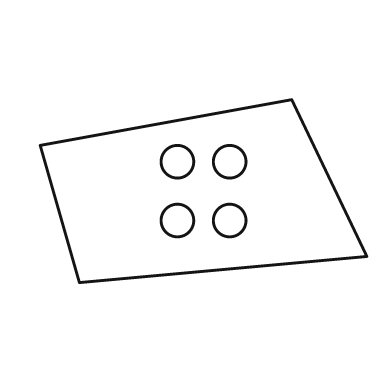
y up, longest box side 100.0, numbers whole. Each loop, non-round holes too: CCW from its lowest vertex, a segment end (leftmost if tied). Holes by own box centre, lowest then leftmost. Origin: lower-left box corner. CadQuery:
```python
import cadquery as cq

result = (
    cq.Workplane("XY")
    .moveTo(12.0, 0.0)
    .lineTo(100.0, 8.0)
    .lineTo(77.0, 56.0)
    .lineTo(0.0, 42.0)
    .close()
    .moveTo(42.0, 19.0)
    .circle(5.0)
    .moveTo(58.0, 19.0)
    .circle(5.0)
    .moveTo(42.0, 37.0)
    .circle(5.0)
    .moveTo(58.0, 37.0)
    .circle(5.0)
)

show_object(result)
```